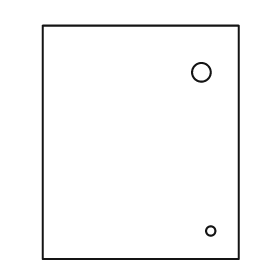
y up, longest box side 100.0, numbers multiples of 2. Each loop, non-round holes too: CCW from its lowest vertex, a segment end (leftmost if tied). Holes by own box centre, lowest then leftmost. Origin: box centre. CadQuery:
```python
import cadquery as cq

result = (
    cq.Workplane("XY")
    .moveTo(-42.0, -50.0)
    .lineTo(42.0, -50.0)
    .lineTo(42.0, 50.0)
    .lineTo(-42.0, 50.0)
    .close()
    .moveTo(30.0, -38.0)
    .circle(2.0)
    .moveTo(26.0, 30.0)
    .circle(4.0)
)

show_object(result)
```